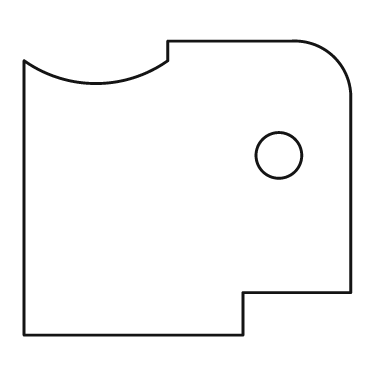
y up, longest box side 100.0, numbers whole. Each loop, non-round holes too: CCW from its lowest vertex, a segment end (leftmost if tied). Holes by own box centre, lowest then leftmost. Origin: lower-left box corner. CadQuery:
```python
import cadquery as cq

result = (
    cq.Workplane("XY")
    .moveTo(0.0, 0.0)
    .lineTo(67.0, 0.0)
    .lineTo(67.0, 13.0)
    .lineTo(100.0, 13.0)
    .lineTo(100.0, 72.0)
    .threePointArc((95.0, 85.0), (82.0, 90.0))
    .lineTo(44.0, 90.0)
    .lineTo(44.0, 84.0)
    .threePointArc((22.0, 77.0), (0.0, 84.0))
    .close()
    .moveTo(78.0, 55.0)
    .circle(7.0)
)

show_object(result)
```